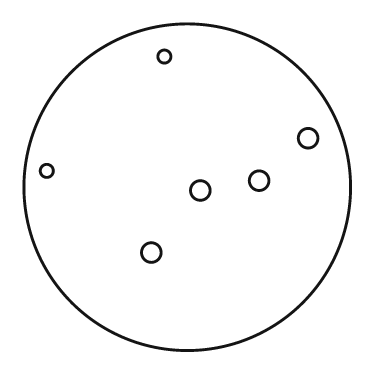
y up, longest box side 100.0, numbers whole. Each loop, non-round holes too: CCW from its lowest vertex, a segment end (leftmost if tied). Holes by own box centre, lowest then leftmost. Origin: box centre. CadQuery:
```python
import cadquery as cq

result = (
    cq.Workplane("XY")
    .moveTo(0.0, 0.0)
    .circle(50.0)
    .moveTo(-11.0, -20.0)
    .circle(3.0)
    .moveTo(4.0, -1.0)
    .circle(3.0)
    .moveTo(22.0, 2.0)
    .circle(3.0)
    .moveTo(-43.0, 5.0)
    .circle(2.0)
    .moveTo(37.0, 15.0)
    .circle(3.0)
    .moveTo(-7.0, 40.0)
    .circle(2.0)
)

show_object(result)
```